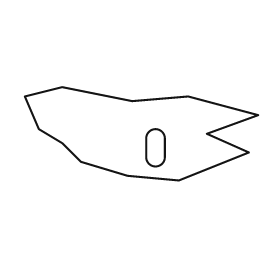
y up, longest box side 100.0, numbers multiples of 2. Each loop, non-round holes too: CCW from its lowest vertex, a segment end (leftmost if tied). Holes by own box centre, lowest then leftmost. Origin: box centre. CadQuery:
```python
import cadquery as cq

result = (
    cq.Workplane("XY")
    .moveTo(16.0, -20.0)
    .lineTo(46.0, -8.0)
    .lineTo(28.0, 0.0)
    .lineTo(50.0, 8.0)
    .lineTo(20.0, 16.0)
    .lineTo(-4.0, 14.0)
    .lineTo(-34.0, 20.0)
    .lineTo(-50.0, 16.0)
    .lineTo(-44.0, 2.0)
    .lineTo(-34.0, -4.0)
    .lineTo(-26.0, -12.0)
    .lineTo(-6.0, -18.0)
    .close()
    .moveTo(2.0, -10.0)
    .threePointArc((6.0, -14.0), (10.0, -10.0))
    .lineTo(10.0, -2.0)
    .threePointArc((6.0, 2.0), (2.0, -2.0))
    .close()
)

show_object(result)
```